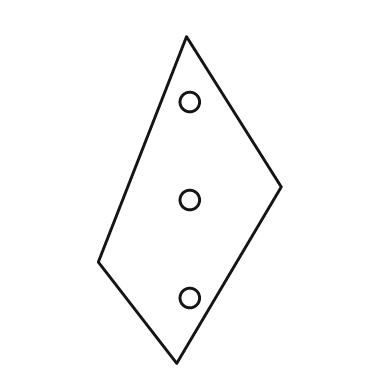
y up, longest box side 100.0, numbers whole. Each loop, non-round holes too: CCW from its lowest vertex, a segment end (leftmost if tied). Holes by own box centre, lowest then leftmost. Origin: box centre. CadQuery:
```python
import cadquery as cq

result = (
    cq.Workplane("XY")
    .moveTo(-4.0, -50.0)
    .lineTo(28.0, 4.0)
    .lineTo(-1.0, 50.0)
    .lineTo(-28.0, -19.0)
    .close()
    .moveTo(0.0, -30.0)
    .circle(3.0)
    .moveTo(0.0, 0.0)
    .circle(3.0)
    .moveTo(0.0, 30.0)
    .circle(3.0)
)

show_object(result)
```